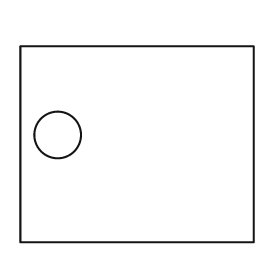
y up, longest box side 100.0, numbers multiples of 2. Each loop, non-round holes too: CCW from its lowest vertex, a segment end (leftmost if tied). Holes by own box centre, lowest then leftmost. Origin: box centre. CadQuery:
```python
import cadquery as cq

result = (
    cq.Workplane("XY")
    .moveTo(-50.0, -42.0)
    .lineTo(50.0, -42.0)
    .lineTo(50.0, 42.0)
    .lineTo(-50.0, 42.0)
    .close()
    .moveTo(-34.0, 4.0)
    .circle(10.0)
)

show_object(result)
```